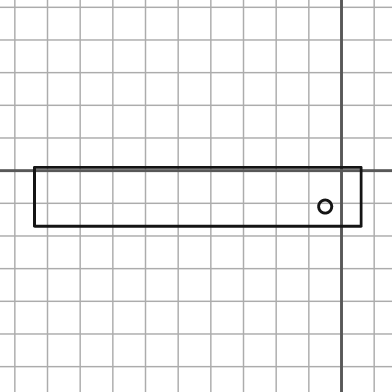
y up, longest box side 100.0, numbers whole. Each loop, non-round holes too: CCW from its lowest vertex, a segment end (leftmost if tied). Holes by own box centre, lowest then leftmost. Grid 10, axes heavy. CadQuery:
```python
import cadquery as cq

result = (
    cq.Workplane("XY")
    .moveTo(-94.0, -17.0)
    .lineTo(6.0, -17.0)
    .lineTo(6.0, 1.0)
    .lineTo(-94.0, 1.0)
    .close()
    .moveTo(-5.0, -11.0)
    .circle(2.0)
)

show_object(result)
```